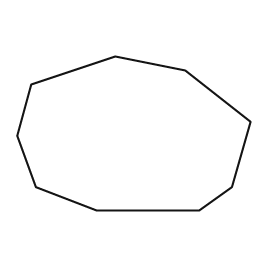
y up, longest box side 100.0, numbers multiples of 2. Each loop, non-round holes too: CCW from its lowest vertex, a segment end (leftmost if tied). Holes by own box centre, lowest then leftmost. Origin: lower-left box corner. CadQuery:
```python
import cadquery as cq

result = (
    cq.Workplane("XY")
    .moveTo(34.0, 0.0)
    .lineTo(78.0, 0.0)
    .lineTo(92.0, 10.0)
    .lineTo(100.0, 38.0)
    .lineTo(72.0, 60.0)
    .lineTo(42.0, 66.0)
    .lineTo(6.0, 54.0)
    .lineTo(0.0, 32.0)
    .lineTo(8.0, 10.0)
    .close()
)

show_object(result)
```